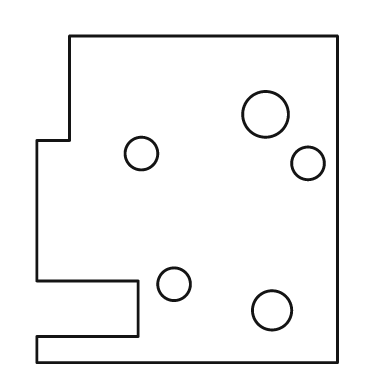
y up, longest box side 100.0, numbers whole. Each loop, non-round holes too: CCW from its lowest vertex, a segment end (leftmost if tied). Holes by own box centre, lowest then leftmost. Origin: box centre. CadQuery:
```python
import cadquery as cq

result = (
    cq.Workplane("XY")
    .moveTo(-46.0, -50.0)
    .lineTo(46.0, -50.0)
    .lineTo(46.0, 50.0)
    .lineTo(-36.0, 50.0)
    .lineTo(-36.0, 18.0)
    .lineTo(-46.0, 18.0)
    .lineTo(-46.0, -25.0)
    .lineTo(-15.0, -25.0)
    .lineTo(-15.0, -42.0)
    .lineTo(-46.0, -42.0)
    .close()
    .moveTo(26.0, -34.0)
    .circle(6.0)
    .moveTo(-4.0, -26.0)
    .circle(5.0)
    .moveTo(37.0, 11.0)
    .circle(5.0)
    .moveTo(-14.0, 14.0)
    .circle(5.0)
    .moveTo(24.0, 26.0)
    .circle(7.0)
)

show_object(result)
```